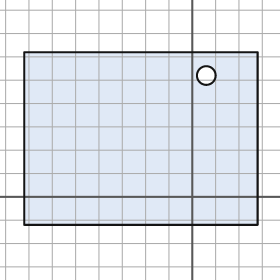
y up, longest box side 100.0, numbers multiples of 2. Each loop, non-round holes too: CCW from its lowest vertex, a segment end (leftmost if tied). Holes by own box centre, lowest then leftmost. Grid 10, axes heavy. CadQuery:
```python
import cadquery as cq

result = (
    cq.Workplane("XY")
    .moveTo(-72.0, -12.0)
    .lineTo(28.0, -12.0)
    .lineTo(28.0, 62.0)
    .lineTo(-72.0, 62.0)
    .close()
    .moveTo(6.0, 52.0)
    .circle(4.0)
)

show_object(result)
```